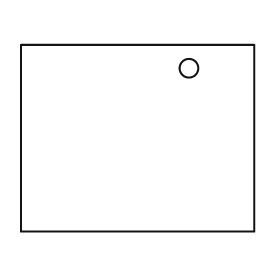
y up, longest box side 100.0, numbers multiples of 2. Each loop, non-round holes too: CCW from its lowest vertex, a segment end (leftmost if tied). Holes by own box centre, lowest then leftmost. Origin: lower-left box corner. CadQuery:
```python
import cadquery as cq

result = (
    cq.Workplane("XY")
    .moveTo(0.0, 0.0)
    .lineTo(100.0, 0.0)
    .lineTo(100.0, 80.0)
    .lineTo(0.0, 80.0)
    .close()
    .moveTo(72.0, 70.0)
    .circle(4.0)
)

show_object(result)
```